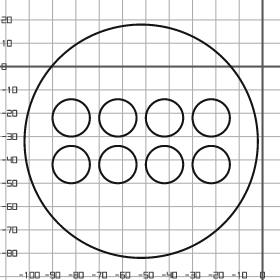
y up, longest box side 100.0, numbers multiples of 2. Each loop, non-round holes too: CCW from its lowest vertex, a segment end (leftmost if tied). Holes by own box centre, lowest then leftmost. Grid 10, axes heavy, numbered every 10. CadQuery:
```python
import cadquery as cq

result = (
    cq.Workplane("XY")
    .moveTo(-52.0, -32.0)
    .circle(50.0)
    .moveTo(-82.0, -42.0)
    .circle(8.0)
    .moveTo(-62.0, -42.0)
    .circle(8.0)
    .moveTo(-42.0, -42.0)
    .circle(8.0)
    .moveTo(-22.0, -42.0)
    .circle(8.0)
    .moveTo(-82.0, -22.0)
    .circle(8.0)
    .moveTo(-62.0, -22.0)
    .circle(8.0)
    .moveTo(-42.0, -22.0)
    .circle(8.0)
    .moveTo(-22.0, -22.0)
    .circle(8.0)
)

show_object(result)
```